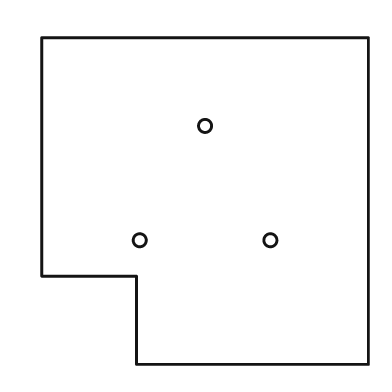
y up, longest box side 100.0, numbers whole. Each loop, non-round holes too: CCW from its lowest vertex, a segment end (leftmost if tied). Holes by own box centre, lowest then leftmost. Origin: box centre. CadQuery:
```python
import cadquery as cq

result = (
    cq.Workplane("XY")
    .moveTo(-21.0, -50.0)
    .lineTo(50.0, -50.0)
    .lineTo(50.0, 50.0)
    .lineTo(-50.0, 50.0)
    .lineTo(-50.0, -23.0)
    .lineTo(-21.0, -23.0)
    .close()
    .moveTo(-20.0, -12.0)
    .circle(2.0)
    .moveTo(20.0, -12.0)
    .circle(2.0)
    .moveTo(0.0, 23.0)
    .circle(2.0)
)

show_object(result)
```